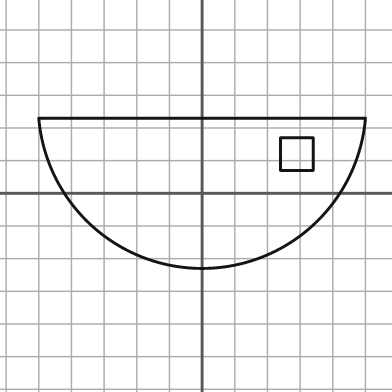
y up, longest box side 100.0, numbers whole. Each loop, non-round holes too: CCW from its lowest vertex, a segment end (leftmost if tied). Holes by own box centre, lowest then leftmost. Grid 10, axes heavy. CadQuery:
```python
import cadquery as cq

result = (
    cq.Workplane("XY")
    .moveTo(-50.0, 23.0)
    .threePointArc((0.0, -23.0), (50.0, 23.0))
    .close()
    .moveTo(24.0, 7.0)
    .lineTo(34.0, 7.0)
    .lineTo(34.0, 17.0)
    .lineTo(24.0, 17.0)
    .close()
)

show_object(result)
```